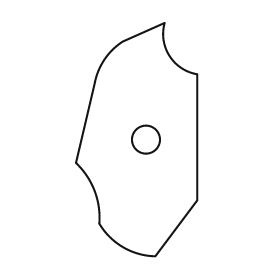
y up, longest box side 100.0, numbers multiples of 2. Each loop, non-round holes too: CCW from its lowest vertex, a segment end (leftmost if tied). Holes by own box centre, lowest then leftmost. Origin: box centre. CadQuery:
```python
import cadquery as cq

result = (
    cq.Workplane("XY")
    .moveTo(8.0, -50.0)
    .lineTo(26.0, -26.0)
    .lineTo(26.0, 28.0)
    .threePointArc((14.0, 36.0), (12.0, 50.0))
    .lineTo(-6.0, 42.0)
    .threePointArc((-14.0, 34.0), (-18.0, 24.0))
    .lineTo(-26.0, -10.0)
    .threePointArc((-18.0, -22.0), (-16.0, -36.0))
    .threePointArc((-6.0, -46.0), (8.0, -50.0))
    .close()
    .moveTo(4.0, 0.0)
    .circle(6.0)
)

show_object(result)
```